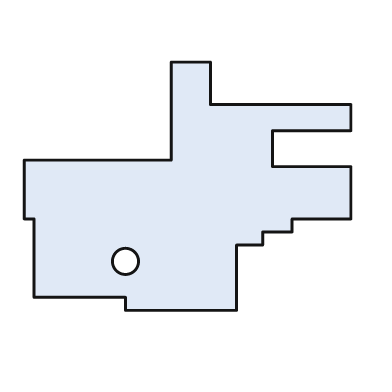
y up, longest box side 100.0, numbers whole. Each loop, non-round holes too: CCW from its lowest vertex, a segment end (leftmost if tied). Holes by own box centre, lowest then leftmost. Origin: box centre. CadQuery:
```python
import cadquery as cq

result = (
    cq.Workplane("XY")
    .moveTo(-19.0, -38.0)
    .lineTo(15.0, -38.0)
    .lineTo(15.0, -18.0)
    .lineTo(23.0, -18.0)
    .lineTo(23.0, -14.0)
    .lineTo(32.0, -14.0)
    .lineTo(32.0, -10.0)
    .lineTo(50.0, -10.0)
    .lineTo(50.0, 6.0)
    .lineTo(26.0, 6.0)
    .lineTo(26.0, 17.0)
    .lineTo(50.0, 17.0)
    .lineTo(50.0, 25.0)
    .lineTo(7.0, 25.0)
    .lineTo(7.0, 38.0)
    .lineTo(-5.0, 38.0)
    .lineTo(-5.0, 8.0)
    .lineTo(-50.0, 8.0)
    .lineTo(-50.0, -10.0)
    .lineTo(-47.0, -10.0)
    .lineTo(-47.0, -34.0)
    .lineTo(-19.0, -34.0)
    .close()
    .moveTo(-19.0, -23.0)
    .circle(4.0)
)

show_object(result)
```